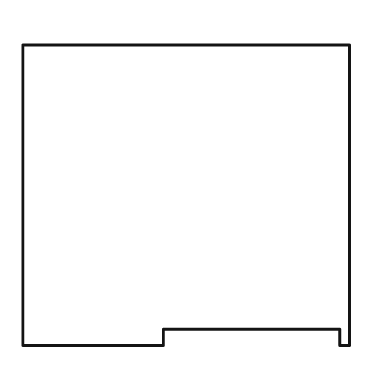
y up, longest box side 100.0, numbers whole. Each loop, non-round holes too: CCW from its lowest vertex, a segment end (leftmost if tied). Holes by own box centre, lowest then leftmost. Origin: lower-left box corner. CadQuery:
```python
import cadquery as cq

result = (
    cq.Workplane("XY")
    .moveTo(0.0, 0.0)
    .lineTo(43.0, 0.0)
    .lineTo(43.0, 5.0)
    .lineTo(97.0, 5.0)
    .lineTo(97.0, 0.0)
    .lineTo(100.0, 0.0)
    .lineTo(100.0, 92.0)
    .lineTo(0.0, 92.0)
    .close()
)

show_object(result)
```